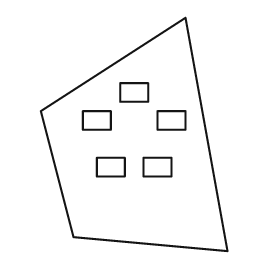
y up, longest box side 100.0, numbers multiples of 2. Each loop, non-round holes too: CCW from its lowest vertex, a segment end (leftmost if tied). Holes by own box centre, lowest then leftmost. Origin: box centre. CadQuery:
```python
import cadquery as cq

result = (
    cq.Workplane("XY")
    .moveTo(40.0, -50.0)
    .lineTo(22.0, 50.0)
    .lineTo(-40.0, 10.0)
    .lineTo(-26.0, -44.0)
    .close()
    .moveTo(-16.0, -18.0)
    .lineTo(-4.0, -18.0)
    .lineTo(-4.0, -10.0)
    .lineTo(-16.0, -10.0)
    .close()
    .moveTo(4.0, -18.0)
    .lineTo(16.0, -18.0)
    .lineTo(16.0, -10.0)
    .lineTo(4.0, -10.0)
    .close()
    .moveTo(-22.0, 2.0)
    .lineTo(-10.0, 2.0)
    .lineTo(-10.0, 10.0)
    .lineTo(-22.0, 10.0)
    .close()
    .moveTo(10.0, 2.0)
    .lineTo(22.0, 2.0)
    .lineTo(22.0, 10.0)
    .lineTo(10.0, 10.0)
    .close()
    .moveTo(-6.0, 14.0)
    .lineTo(6.0, 14.0)
    .lineTo(6.0, 22.0)
    .lineTo(-6.0, 22.0)
    .close()
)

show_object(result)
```